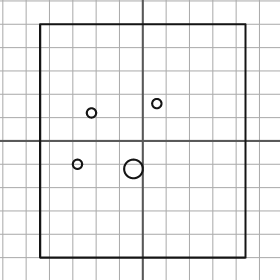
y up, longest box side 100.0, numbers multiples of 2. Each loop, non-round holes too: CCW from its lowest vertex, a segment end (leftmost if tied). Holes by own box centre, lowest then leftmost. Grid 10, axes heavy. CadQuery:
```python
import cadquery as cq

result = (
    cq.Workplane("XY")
    .moveTo(-44.0, -50.0)
    .lineTo(44.0, -50.0)
    .lineTo(44.0, 50.0)
    .lineTo(-44.0, 50.0)
    .close()
    .moveTo(-4.0, -12.0)
    .circle(4.0)
    .moveTo(-28.0, -10.0)
    .circle(2.0)
    .moveTo(-22.0, 12.0)
    .circle(2.0)
    .moveTo(6.0, 16.0)
    .circle(2.0)
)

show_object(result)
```